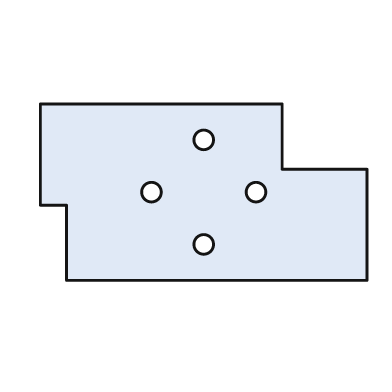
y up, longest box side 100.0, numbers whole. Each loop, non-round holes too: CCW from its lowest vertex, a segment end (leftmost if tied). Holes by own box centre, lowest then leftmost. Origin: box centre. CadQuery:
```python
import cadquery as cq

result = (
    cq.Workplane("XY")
    .moveTo(-42.0, -27.0)
    .lineTo(50.0, -27.0)
    .lineTo(50.0, 7.0)
    .lineTo(24.0, 7.0)
    .lineTo(24.0, 27.0)
    .lineTo(-50.0, 27.0)
    .lineTo(-50.0, -4.0)
    .lineTo(-42.0, -4.0)
    .close()
    .moveTo(0.0, -16.0)
    .circle(3.0)
    .moveTo(-16.0, 0.0)
    .circle(3.0)
    .moveTo(16.0, 0.0)
    .circle(3.0)
    .moveTo(0.0, 16.0)
    .circle(3.0)
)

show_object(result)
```